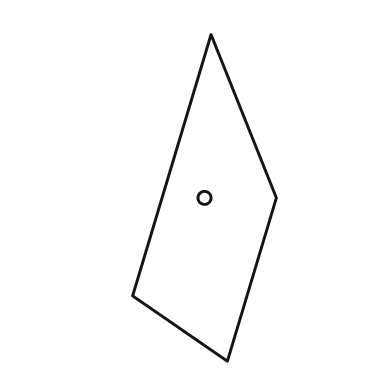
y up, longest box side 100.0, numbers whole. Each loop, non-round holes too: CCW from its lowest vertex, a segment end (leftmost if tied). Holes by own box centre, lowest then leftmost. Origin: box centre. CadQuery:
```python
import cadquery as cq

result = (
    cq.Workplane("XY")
    .moveTo(7.0, -50.0)
    .lineTo(22.0, 0.0)
    .lineTo(2.0, 50.0)
    .lineTo(-22.0, -30.0)
    .close()
    .moveTo(0.0, 0.0)
    .circle(2.0)
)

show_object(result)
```